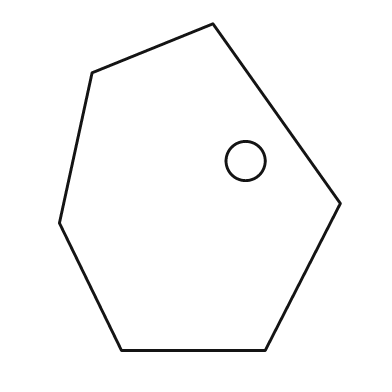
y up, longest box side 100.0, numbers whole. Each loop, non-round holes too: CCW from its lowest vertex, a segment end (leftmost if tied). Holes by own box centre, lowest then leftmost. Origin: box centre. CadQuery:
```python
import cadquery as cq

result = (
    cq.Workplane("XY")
    .moveTo(-24.0, -50.0)
    .lineTo(20.0, -50.0)
    .lineTo(43.0, -5.0)
    .lineTo(4.0, 50.0)
    .lineTo(-33.0, 35.0)
    .lineTo(-43.0, -11.0)
    .close()
    .moveTo(14.0, 8.0)
    .circle(6.0)
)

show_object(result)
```